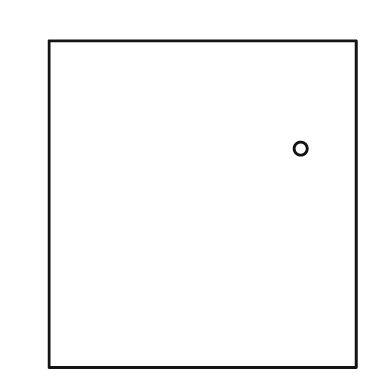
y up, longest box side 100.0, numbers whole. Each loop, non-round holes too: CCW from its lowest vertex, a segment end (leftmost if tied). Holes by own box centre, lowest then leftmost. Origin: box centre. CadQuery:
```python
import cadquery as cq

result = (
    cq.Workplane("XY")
    .moveTo(-47.0, -50.0)
    .lineTo(47.0, -50.0)
    .lineTo(47.0, 50.0)
    .lineTo(-47.0, 50.0)
    .close()
    .moveTo(30.0, 17.0)
    .circle(2.0)
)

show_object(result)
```